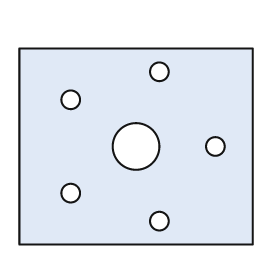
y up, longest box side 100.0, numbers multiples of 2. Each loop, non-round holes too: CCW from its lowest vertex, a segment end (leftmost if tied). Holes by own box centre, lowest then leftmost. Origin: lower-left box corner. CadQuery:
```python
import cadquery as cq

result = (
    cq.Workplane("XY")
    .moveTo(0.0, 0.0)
    .lineTo(100.0, 0.0)
    .lineTo(100.0, 84.0)
    .lineTo(0.0, 84.0)
    .close()
    .moveTo(60.0, 10.0)
    .circle(4.0)
    .moveTo(22.0, 22.0)
    .circle(4.0)
    .moveTo(50.0, 42.0)
    .circle(10.0)
    .moveTo(84.0, 42.0)
    .circle(4.0)
    .moveTo(22.0, 62.0)
    .circle(4.0)
    .moveTo(60.0, 74.0)
    .circle(4.0)
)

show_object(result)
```